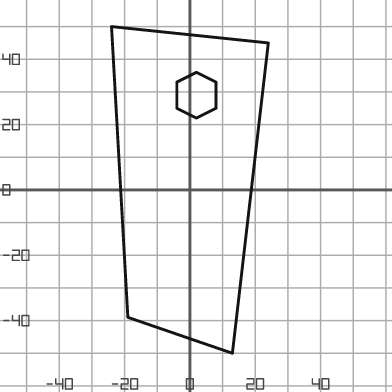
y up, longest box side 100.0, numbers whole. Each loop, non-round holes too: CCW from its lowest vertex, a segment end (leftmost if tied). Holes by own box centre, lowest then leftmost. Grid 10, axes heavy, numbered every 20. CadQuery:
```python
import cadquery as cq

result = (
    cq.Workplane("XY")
    .moveTo(13.0, -50.0)
    .lineTo(24.0, 45.0)
    .lineTo(-24.0, 50.0)
    .lineTo(-19.0, -39.0)
    .close()
    .moveTo(2.0, 22.0)
    .lineTo(8.0, 25.0)
    .lineTo(8.0, 33.0)
    .lineTo(2.0, 36.0)
    .lineTo(-4.0, 33.0)
    .lineTo(-4.0, 25.0)
    .close()
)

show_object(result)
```